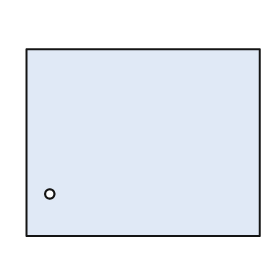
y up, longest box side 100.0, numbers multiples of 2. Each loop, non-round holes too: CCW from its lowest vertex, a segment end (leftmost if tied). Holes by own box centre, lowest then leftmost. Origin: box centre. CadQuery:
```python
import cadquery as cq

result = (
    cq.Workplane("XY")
    .moveTo(-50.0, -40.0)
    .lineTo(50.0, -40.0)
    .lineTo(50.0, 40.0)
    .lineTo(-50.0, 40.0)
    .close()
    .moveTo(-40.0, -22.0)
    .circle(2.0)
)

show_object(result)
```